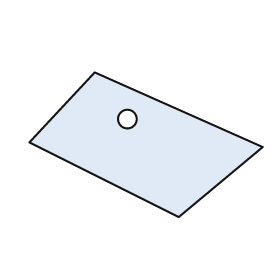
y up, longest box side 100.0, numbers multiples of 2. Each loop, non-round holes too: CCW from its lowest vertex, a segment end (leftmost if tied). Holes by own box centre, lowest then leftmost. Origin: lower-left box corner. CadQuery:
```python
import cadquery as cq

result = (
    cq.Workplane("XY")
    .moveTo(64.0, 0.0)
    .lineTo(100.0, 30.0)
    .lineTo(28.0, 62.0)
    .lineTo(0.0, 32.0)
    .close()
    .moveTo(42.0, 42.0)
    .circle(4.0)
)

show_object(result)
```